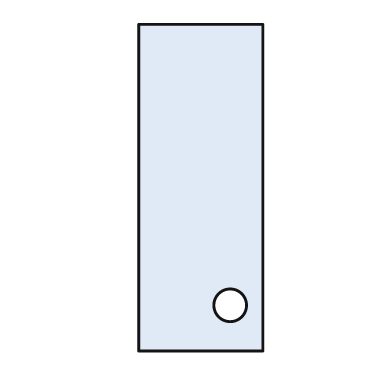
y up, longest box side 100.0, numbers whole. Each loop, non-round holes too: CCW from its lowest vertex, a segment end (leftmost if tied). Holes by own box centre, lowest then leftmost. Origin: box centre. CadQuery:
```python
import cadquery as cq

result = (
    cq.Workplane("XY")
    .moveTo(-19.0, -50.0)
    .lineTo(19.0, -50.0)
    .lineTo(19.0, 50.0)
    .lineTo(-19.0, 50.0)
    .close()
    .moveTo(9.0, -36.0)
    .circle(5.0)
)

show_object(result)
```